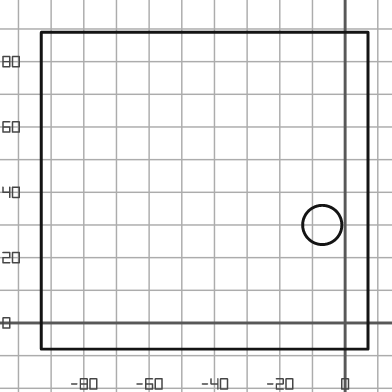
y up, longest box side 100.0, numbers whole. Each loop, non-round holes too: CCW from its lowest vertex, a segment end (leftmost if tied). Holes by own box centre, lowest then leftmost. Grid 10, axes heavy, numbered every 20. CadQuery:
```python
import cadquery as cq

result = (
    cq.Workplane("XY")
    .moveTo(-93.0, -8.0)
    .lineTo(7.0, -8.0)
    .lineTo(7.0, 89.0)
    .lineTo(-93.0, 89.0)
    .close()
    .moveTo(-7.0, 30.0)
    .circle(6.0)
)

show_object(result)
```